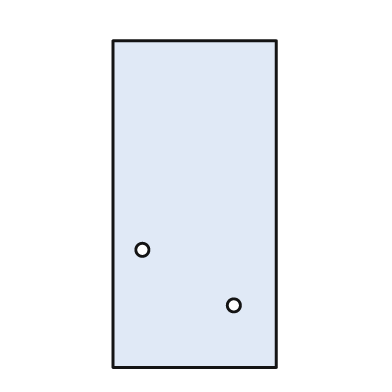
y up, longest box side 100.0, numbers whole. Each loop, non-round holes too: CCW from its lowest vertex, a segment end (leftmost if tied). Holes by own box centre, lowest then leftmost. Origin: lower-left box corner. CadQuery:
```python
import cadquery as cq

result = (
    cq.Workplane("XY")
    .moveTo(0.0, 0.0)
    .lineTo(50.0, 0.0)
    .lineTo(50.0, 100.0)
    .lineTo(0.0, 100.0)
    .close()
    .moveTo(37.0, 19.0)
    .circle(2.0)
    .moveTo(9.0, 36.0)
    .circle(2.0)
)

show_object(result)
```